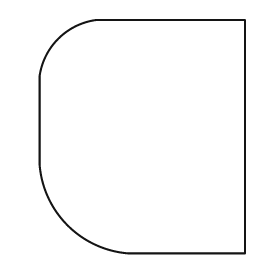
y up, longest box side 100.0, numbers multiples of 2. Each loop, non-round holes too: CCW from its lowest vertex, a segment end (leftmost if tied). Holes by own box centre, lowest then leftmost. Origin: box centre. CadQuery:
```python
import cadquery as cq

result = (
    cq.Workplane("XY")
    .moveTo(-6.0, -50.0)
    .lineTo(44.0, -50.0)
    .lineTo(44.0, 50.0)
    .lineTo(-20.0, 50.0)
    .threePointArc((-36.0, 42.0), (-44.0, 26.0))
    .lineTo(-44.0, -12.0)
    .threePointArc((-32.0, -38.0), (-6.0, -50.0))
    .close()
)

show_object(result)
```